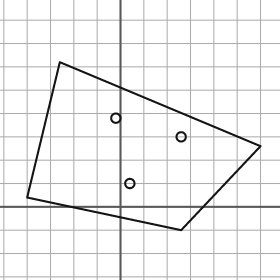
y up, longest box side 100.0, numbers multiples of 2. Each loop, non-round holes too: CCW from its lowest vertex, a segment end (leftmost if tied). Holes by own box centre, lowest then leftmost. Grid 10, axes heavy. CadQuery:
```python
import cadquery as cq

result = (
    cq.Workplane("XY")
    .moveTo(26.0, -10.0)
    .lineTo(60.0, 26.0)
    .lineTo(-26.0, 62.0)
    .lineTo(-40.0, 4.0)
    .close()
    .moveTo(4.0, 10.0)
    .circle(2.0)
    .moveTo(26.0, 30.0)
    .circle(2.0)
    .moveTo(-2.0, 38.0)
    .circle(2.0)
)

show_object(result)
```